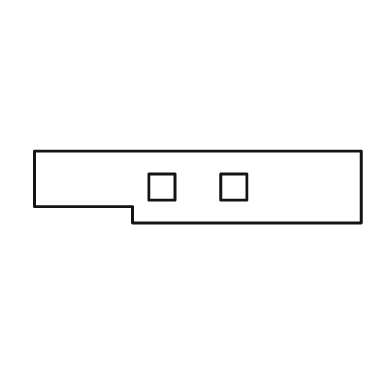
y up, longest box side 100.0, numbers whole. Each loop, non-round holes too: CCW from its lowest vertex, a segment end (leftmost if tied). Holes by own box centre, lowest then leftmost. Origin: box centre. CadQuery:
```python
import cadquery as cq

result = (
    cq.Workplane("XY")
    .moveTo(-20.0, -11.0)
    .lineTo(50.0, -11.0)
    .lineTo(50.0, 11.0)
    .lineTo(-50.0, 11.0)
    .lineTo(-50.0, -6.0)
    .lineTo(-20.0, -6.0)
    .close()
    .moveTo(-15.0, -4.0)
    .lineTo(-7.0, -4.0)
    .lineTo(-7.0, 4.0)
    .lineTo(-15.0, 4.0)
    .close()
    .moveTo(7.0, -4.0)
    .lineTo(15.0, -4.0)
    .lineTo(15.0, 4.0)
    .lineTo(7.0, 4.0)
    .close()
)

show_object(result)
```